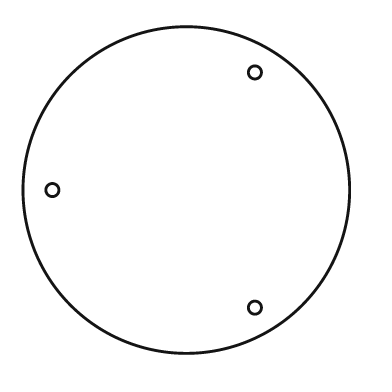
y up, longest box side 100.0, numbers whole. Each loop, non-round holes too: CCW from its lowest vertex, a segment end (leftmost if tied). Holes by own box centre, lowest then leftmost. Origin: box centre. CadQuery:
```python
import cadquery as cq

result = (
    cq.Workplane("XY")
    .moveTo(0.0, 0.0)
    .circle(50.0)
    .moveTo(21.0, -36.0)
    .circle(2.0)
    .moveTo(-41.0, 0.0)
    .circle(2.0)
    .moveTo(21.0, 36.0)
    .circle(2.0)
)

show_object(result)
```